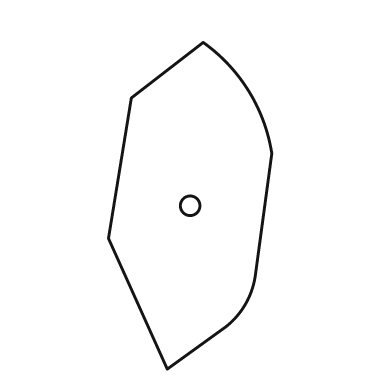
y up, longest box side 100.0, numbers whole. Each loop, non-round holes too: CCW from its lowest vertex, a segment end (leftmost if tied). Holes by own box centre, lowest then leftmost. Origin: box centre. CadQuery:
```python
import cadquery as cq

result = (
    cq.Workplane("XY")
    .moveTo(-7.0, -50.0)
    .lineTo(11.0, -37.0)
    .threePointArc((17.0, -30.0), (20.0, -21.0))
    .lineTo(25.0, 16.0)
    .threePointArc((18.0, 35.0), (4.0, 50.0))
    .lineTo(-18.0, 33.0)
    .lineTo(-25.0, -10.0)
    .close()
    .moveTo(0.0, 0.0)
    .circle(3.0)
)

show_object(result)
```